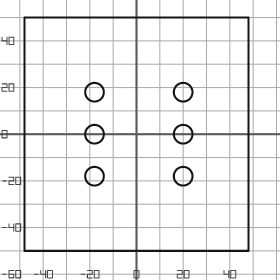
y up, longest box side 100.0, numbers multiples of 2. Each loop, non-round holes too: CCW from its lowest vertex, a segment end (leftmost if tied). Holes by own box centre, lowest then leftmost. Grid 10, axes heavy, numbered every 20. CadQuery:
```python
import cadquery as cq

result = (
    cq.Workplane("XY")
    .moveTo(-48.0, -50.0)
    .lineTo(48.0, -50.0)
    .lineTo(48.0, 50.0)
    .lineTo(-48.0, 50.0)
    .close()
    .moveTo(-18.0, -18.0)
    .circle(4.0)
    .moveTo(20.0, -18.0)
    .circle(4.0)
    .moveTo(-18.0, 0.0)
    .circle(4.0)
    .moveTo(20.0, 0.0)
    .circle(4.0)
    .moveTo(-18.0, 18.0)
    .circle(4.0)
    .moveTo(20.0, 18.0)
    .circle(4.0)
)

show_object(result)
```